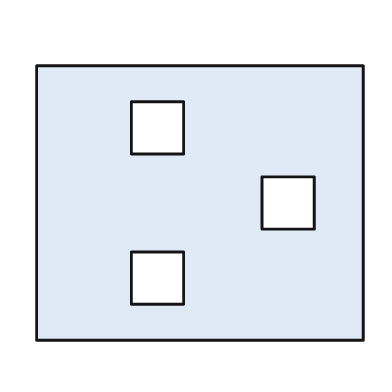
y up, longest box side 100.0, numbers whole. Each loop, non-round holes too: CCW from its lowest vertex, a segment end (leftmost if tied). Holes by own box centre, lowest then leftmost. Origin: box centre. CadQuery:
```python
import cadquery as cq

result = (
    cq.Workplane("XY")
    .moveTo(-50.0, -42.0)
    .lineTo(50.0, -42.0)
    .lineTo(50.0, 42.0)
    .lineTo(-50.0, 42.0)
    .close()
    .moveTo(-21.0, -31.0)
    .lineTo(-5.0, -31.0)
    .lineTo(-5.0, -15.0)
    .lineTo(-21.0, -15.0)
    .close()
    .moveTo(19.0, -8.0)
    .lineTo(35.0, -8.0)
    .lineTo(35.0, 8.0)
    .lineTo(19.0, 8.0)
    .close()
    .moveTo(-21.0, 15.0)
    .lineTo(-5.0, 15.0)
    .lineTo(-5.0, 31.0)
    .lineTo(-21.0, 31.0)
    .close()
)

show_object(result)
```